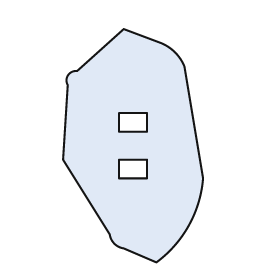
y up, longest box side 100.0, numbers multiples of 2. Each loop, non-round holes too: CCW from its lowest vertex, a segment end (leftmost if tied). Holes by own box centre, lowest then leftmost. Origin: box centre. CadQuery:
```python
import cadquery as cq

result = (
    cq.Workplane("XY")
    .moveTo(10.0, -50.0)
    .threePointArc((24.0, -34.0), (30.0, -14.0))
    .lineTo(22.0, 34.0)
    .threePointArc((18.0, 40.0), (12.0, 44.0))
    .lineTo(-4.0, 50.0)
    .lineTo(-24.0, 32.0)
    .threePointArc((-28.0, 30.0), (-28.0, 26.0))
    .lineTo(-30.0, -6.0)
    .lineTo(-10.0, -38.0)
    .threePointArc((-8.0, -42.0), (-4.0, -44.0))
    .close()
    .moveTo(-6.0, -14.0)
    .lineTo(6.0, -14.0)
    .lineTo(6.0, -6.0)
    .lineTo(-6.0, -6.0)
    .close()
    .moveTo(-6.0, 6.0)
    .lineTo(6.0, 6.0)
    .lineTo(6.0, 14.0)
    .lineTo(-6.0, 14.0)
    .close()
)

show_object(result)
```